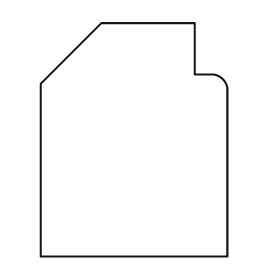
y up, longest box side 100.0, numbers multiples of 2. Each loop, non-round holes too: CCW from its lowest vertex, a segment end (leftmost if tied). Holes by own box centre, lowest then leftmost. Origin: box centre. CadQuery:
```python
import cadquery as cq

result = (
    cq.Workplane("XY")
    .moveTo(-40.0, -50.0)
    .lineTo(40.0, -50.0)
    .lineTo(40.0, 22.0)
    .threePointArc((38.0, 26.0), (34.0, 28.0))
    .lineTo(26.0, 28.0)
    .lineTo(26.0, 50.0)
    .lineTo(-14.0, 50.0)
    .lineTo(-40.0, 24.0)
    .close()
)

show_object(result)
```